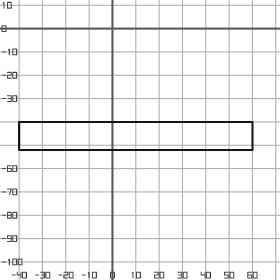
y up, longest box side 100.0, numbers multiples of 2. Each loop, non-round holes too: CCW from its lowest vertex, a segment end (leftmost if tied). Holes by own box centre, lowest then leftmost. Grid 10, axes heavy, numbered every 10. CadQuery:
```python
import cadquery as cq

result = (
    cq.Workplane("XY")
    .moveTo(-40.0, -52.0)
    .lineTo(60.0, -52.0)
    .lineTo(60.0, -40.0)
    .lineTo(-40.0, -40.0)
    .close()
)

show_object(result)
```